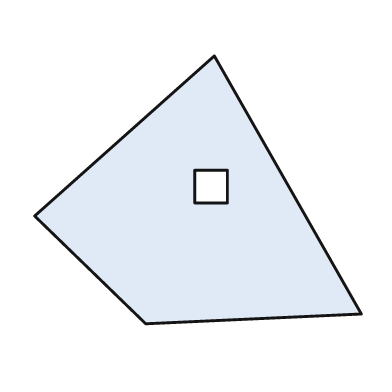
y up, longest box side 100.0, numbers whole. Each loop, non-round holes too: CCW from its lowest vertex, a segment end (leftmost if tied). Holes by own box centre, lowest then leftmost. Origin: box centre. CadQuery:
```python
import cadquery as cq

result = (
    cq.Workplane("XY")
    .moveTo(-16.0, -41.0)
    .lineTo(50.0, -38.0)
    .lineTo(5.0, 41.0)
    .lineTo(-50.0, -8.0)
    .close()
    .moveTo(-1.0, -4.0)
    .lineTo(9.0, -4.0)
    .lineTo(9.0, 6.0)
    .lineTo(-1.0, 6.0)
    .close()
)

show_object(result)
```